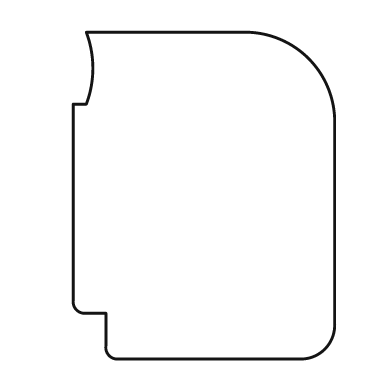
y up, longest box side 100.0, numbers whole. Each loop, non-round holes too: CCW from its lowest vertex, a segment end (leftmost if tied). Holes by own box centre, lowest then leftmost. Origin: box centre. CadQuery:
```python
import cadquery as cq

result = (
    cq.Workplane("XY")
    .moveTo(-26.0, -50.0)
    .lineTo(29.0, -50.0)
    .threePointArc((37.0, -47.0), (40.0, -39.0))
    .lineTo(40.0, 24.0)
    .threePointArc((32.0, 42.0), (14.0, 50.0))
    .lineTo(-36.0, 50.0)
    .threePointArc((-34.0, 39.0), (-36.0, 28.0))
    .lineTo(-40.0, 28.0)
    .lineTo(-40.0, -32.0)
    .threePointArc((-39.0, -35.0), (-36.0, -36.0))
    .lineTo(-30.0, -36.0)
    .lineTo(-30.0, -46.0)
    .threePointArc((-29.0, -49.0), (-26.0, -50.0))
    .close()
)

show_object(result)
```